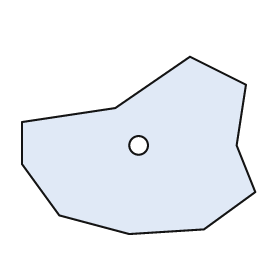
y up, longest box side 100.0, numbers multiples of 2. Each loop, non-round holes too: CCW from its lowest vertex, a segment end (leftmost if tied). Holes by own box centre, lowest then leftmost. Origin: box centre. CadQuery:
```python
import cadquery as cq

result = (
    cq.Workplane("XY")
    .moveTo(-4.0, -38.0)
    .lineTo(28.0, -36.0)
    .lineTo(50.0, -20.0)
    .lineTo(42.0, 0.0)
    .lineTo(46.0, 26.0)
    .lineTo(22.0, 38.0)
    .lineTo(-10.0, 16.0)
    .lineTo(-50.0, 10.0)
    .lineTo(-50.0, -8.0)
    .lineTo(-34.0, -30.0)
    .close()
    .moveTo(0.0, 0.0)
    .circle(4.0)
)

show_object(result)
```